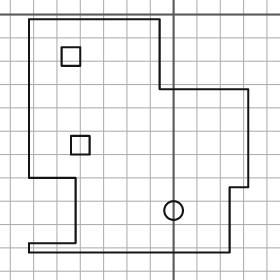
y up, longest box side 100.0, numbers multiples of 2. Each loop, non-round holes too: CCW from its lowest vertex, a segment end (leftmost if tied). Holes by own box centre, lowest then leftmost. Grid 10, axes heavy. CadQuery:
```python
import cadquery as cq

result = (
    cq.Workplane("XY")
    .moveTo(-62.0, -102.0)
    .lineTo(24.0, -102.0)
    .lineTo(24.0, -74.0)
    .lineTo(32.0, -74.0)
    .lineTo(32.0, -32.0)
    .lineTo(-6.0, -32.0)
    .lineTo(-6.0, -2.0)
    .lineTo(-62.0, -2.0)
    .lineTo(-62.0, -70.0)
    .lineTo(-42.0, -70.0)
    .lineTo(-42.0, -98.0)
    .lineTo(-62.0, -98.0)
    .close()
    .moveTo(0.0, -84.0)
    .circle(4.0)
    .moveTo(-44.0, -60.0)
    .lineTo(-36.0, -60.0)
    .lineTo(-36.0, -52.0)
    .lineTo(-44.0, -52.0)
    .close()
    .moveTo(-48.0, -22.0)
    .lineTo(-40.0, -22.0)
    .lineTo(-40.0, -14.0)
    .lineTo(-48.0, -14.0)
    .close()
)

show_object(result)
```